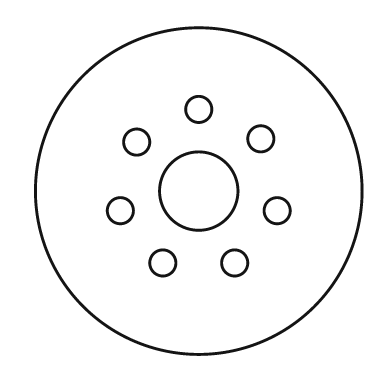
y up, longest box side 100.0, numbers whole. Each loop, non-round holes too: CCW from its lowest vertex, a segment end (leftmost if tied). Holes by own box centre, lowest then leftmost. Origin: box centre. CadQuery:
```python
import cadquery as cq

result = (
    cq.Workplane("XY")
    .moveTo(0.0, 0.0)
    .circle(50.0)
    .moveTo(-11.0, -22.0)
    .circle(4.0)
    .moveTo(11.0, -22.0)
    .circle(4.0)
    .moveTo(-24.0, -6.0)
    .circle(4.0)
    .moveTo(24.0, -6.0)
    .circle(4.0)
    .moveTo(0.0, 0.0)
    .circle(12.0)
    .moveTo(-19.0, 15.0)
    .circle(4.0)
    .moveTo(19.0, 16.0)
    .circle(4.0)
    .moveTo(0.0, 25.0)
    .circle(4.0)
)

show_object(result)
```